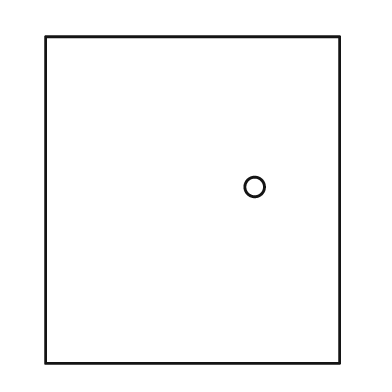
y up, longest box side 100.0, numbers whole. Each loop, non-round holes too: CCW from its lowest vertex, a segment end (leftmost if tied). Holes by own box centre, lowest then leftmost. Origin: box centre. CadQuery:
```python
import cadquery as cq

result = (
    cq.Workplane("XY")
    .moveTo(-45.0, -50.0)
    .lineTo(45.0, -50.0)
    .lineTo(45.0, 50.0)
    .lineTo(-45.0, 50.0)
    .close()
    .moveTo(19.0, 4.0)
    .circle(3.0)
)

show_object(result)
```